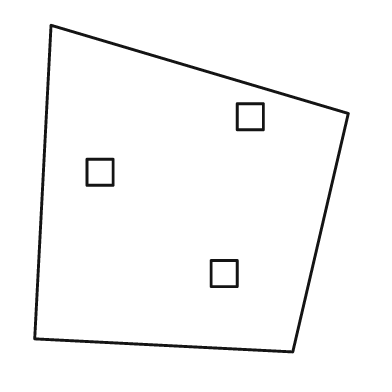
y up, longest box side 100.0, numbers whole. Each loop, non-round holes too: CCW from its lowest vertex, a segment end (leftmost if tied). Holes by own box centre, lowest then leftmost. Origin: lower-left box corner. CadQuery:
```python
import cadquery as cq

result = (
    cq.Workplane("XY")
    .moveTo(79.0, 0.0)
    .lineTo(96.0, 73.0)
    .lineTo(5.0, 100.0)
    .lineTo(0.0, 4.0)
    .close()
    .moveTo(54.0, 20.0)
    .lineTo(62.0, 20.0)
    .lineTo(62.0, 28.0)
    .lineTo(54.0, 28.0)
    .close()
    .moveTo(16.0, 51.0)
    .lineTo(24.0, 51.0)
    .lineTo(24.0, 59.0)
    .lineTo(16.0, 59.0)
    .close()
    .moveTo(62.0, 68.0)
    .lineTo(70.0, 68.0)
    .lineTo(70.0, 76.0)
    .lineTo(62.0, 76.0)
    .close()
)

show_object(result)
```